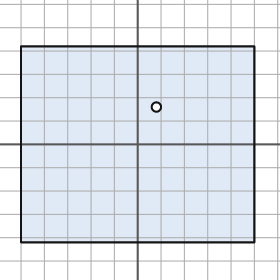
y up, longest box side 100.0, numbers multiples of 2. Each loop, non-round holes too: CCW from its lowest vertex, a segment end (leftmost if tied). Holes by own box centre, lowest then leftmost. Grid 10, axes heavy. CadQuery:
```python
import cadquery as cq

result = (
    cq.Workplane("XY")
    .moveTo(-50.0, -42.0)
    .lineTo(50.0, -42.0)
    .lineTo(50.0, 42.0)
    .lineTo(-50.0, 42.0)
    .close()
    .moveTo(8.0, 16.0)
    .circle(2.0)
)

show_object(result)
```